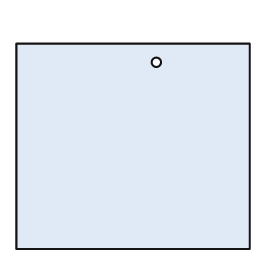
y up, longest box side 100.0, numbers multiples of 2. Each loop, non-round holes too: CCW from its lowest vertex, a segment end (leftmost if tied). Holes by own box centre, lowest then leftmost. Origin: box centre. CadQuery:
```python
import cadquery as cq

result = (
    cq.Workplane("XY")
    .moveTo(-50.0, -44.0)
    .lineTo(50.0, -44.0)
    .lineTo(50.0, 44.0)
    .lineTo(-50.0, 44.0)
    .close()
    .moveTo(10.0, 36.0)
    .circle(2.0)
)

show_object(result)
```